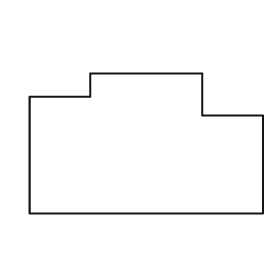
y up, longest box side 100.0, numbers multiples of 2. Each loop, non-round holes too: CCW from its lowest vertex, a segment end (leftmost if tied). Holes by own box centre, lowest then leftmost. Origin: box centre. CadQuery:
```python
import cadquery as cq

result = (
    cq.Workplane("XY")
    .moveTo(-50.0, -30.0)
    .lineTo(50.0, -30.0)
    .lineTo(50.0, 12.0)
    .lineTo(24.0, 12.0)
    .lineTo(24.0, 30.0)
    .lineTo(-24.0, 30.0)
    .lineTo(-24.0, 20.0)
    .lineTo(-50.0, 20.0)
    .close()
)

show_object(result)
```